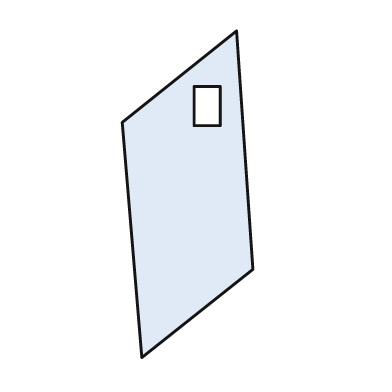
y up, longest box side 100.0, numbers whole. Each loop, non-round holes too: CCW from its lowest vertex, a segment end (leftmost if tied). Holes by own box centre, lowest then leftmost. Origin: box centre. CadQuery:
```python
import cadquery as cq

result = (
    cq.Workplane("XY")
    .moveTo(-14.0, -50.0)
    .lineTo(20.0, -23.0)
    .lineTo(15.0, 50.0)
    .lineTo(-20.0, 22.0)
    .close()
    .moveTo(2.0, 21.0)
    .lineTo(10.0, 21.0)
    .lineTo(10.0, 33.0)
    .lineTo(2.0, 33.0)
    .close()
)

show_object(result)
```